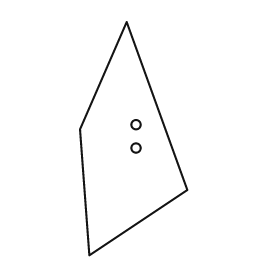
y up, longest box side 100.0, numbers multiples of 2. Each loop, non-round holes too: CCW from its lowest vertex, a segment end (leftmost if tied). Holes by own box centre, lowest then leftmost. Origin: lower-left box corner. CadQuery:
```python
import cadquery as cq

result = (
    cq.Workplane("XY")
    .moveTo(4.0, 0.0)
    .lineTo(46.0, 28.0)
    .lineTo(20.0, 100.0)
    .lineTo(0.0, 54.0)
    .close()
    .moveTo(24.0, 46.0)
    .circle(2.0)
    .moveTo(24.0, 56.0)
    .circle(2.0)
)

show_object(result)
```